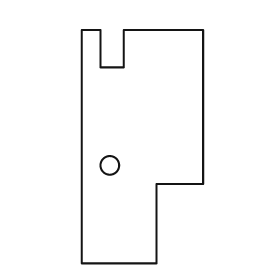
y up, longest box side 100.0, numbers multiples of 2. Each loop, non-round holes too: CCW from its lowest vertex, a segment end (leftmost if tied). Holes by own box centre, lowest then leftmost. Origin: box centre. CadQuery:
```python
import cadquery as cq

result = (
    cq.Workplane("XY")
    .moveTo(-26.0, -50.0)
    .lineTo(6.0, -50.0)
    .lineTo(6.0, -16.0)
    .lineTo(26.0, -16.0)
    .lineTo(26.0, 50.0)
    .lineTo(-8.0, 50.0)
    .lineTo(-8.0, 34.0)
    .lineTo(-18.0, 34.0)
    .lineTo(-18.0, 50.0)
    .lineTo(-26.0, 50.0)
    .close()
    .moveTo(-14.0, -8.0)
    .circle(4.0)
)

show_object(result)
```